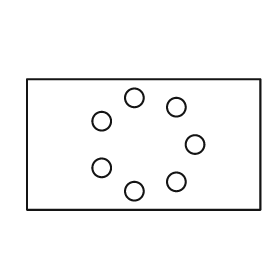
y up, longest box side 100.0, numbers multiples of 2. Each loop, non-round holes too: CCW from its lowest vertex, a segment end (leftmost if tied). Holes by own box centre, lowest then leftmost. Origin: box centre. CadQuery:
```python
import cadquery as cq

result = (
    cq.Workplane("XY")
    .moveTo(-50.0, -28.0)
    .lineTo(50.0, -28.0)
    .lineTo(50.0, 28.0)
    .lineTo(-50.0, 28.0)
    .close()
    .moveTo(-4.0, -20.0)
    .circle(4.0)
    .moveTo(14.0, -16.0)
    .circle(4.0)
    .moveTo(-18.0, -10.0)
    .circle(4.0)
    .moveTo(22.0, 0.0)
    .circle(4.0)
    .moveTo(-18.0, 10.0)
    .circle(4.0)
    .moveTo(14.0, 16.0)
    .circle(4.0)
    .moveTo(-4.0, 20.0)
    .circle(4.0)
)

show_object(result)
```